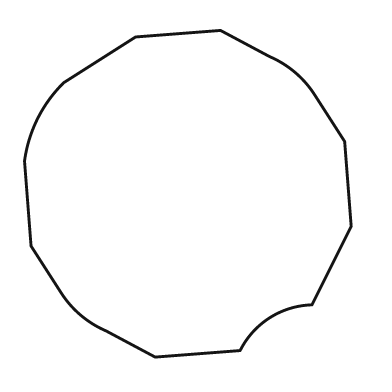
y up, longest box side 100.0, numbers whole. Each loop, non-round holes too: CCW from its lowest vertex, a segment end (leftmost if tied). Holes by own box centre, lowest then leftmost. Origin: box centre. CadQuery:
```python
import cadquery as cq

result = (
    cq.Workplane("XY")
    .moveTo(-10.0, -50.0)
    .lineTo(16.0, -48.0)
    .threePointArc((25.0, -38.0), (38.0, -34.0))
    .lineTo(50.0, -10.0)
    .lineTo(48.0, 16.0)
    .lineTo(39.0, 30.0)
    .threePointArc((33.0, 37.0), (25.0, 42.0))
    .lineTo(10.0, 50.0)
    .lineTo(-16.0, 48.0)
    .lineTo(-38.0, 34.0)
    .threePointArc((-46.0, 23.0), (-50.0, 10.0))
    .lineTo(-48.0, -16.0)
    .lineTo(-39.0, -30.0)
    .threePointArc((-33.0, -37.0), (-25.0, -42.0))
    .close()
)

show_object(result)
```